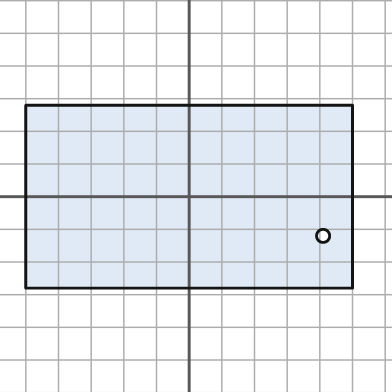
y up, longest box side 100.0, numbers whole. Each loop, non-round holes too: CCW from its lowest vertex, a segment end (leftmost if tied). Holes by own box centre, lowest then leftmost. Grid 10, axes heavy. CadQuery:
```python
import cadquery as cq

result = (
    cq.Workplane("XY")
    .moveTo(-50.0, -28.0)
    .lineTo(50.0, -28.0)
    .lineTo(50.0, 28.0)
    .lineTo(-50.0, 28.0)
    .close()
    .moveTo(41.0, -12.0)
    .circle(2.0)
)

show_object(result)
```